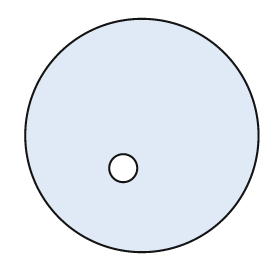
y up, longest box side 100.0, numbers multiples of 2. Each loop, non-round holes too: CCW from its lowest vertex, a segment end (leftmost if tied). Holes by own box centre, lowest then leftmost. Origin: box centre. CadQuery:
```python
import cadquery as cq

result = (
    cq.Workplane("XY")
    .moveTo(0.0, 0.0)
    .circle(50.0)
    .moveTo(-8.0, -14.0)
    .circle(6.0)
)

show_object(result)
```